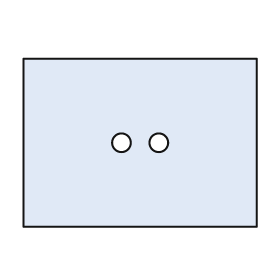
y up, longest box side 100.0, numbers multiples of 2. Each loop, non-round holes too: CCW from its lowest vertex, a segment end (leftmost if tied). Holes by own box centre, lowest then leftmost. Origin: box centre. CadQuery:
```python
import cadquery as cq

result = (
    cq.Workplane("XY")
    .moveTo(-50.0, -36.0)
    .lineTo(50.0, -36.0)
    .lineTo(50.0, 36.0)
    .lineTo(-50.0, 36.0)
    .close()
    .moveTo(-8.0, 0.0)
    .circle(4.0)
    .moveTo(8.0, 0.0)
    .circle(4.0)
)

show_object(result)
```